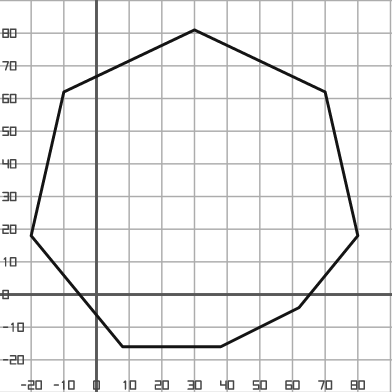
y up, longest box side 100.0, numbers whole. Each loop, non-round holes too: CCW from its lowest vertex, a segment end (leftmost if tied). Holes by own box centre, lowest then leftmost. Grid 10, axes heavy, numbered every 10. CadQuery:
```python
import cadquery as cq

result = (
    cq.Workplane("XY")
    .moveTo(8.0, -16.0)
    .lineTo(38.0, -16.0)
    .lineTo(62.0, -4.0)
    .lineTo(80.0, 18.0)
    .lineTo(70.0, 62.0)
    .lineTo(30.0, 81.0)
    .lineTo(-10.0, 62.0)
    .lineTo(-20.0, 18.0)
    .close()
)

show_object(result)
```